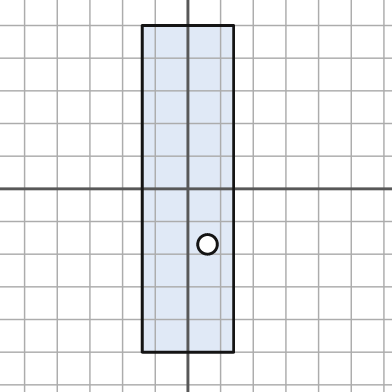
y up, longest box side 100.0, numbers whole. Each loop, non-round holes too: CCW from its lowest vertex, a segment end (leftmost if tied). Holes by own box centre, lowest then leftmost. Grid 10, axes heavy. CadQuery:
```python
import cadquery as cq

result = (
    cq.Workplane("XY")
    .moveTo(-14.0, -50.0)
    .lineTo(14.0, -50.0)
    .lineTo(14.0, 50.0)
    .lineTo(-14.0, 50.0)
    .close()
    .moveTo(6.0, -17.0)
    .circle(3.0)
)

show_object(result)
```